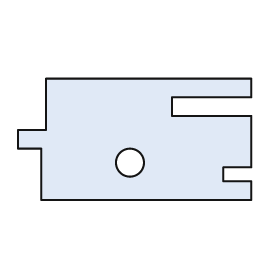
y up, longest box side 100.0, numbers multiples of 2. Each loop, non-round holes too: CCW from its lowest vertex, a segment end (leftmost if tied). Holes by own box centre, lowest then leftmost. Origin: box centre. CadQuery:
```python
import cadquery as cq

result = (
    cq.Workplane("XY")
    .moveTo(-40.0, -26.0)
    .lineTo(50.0, -26.0)
    .lineTo(50.0, -18.0)
    .lineTo(38.0, -18.0)
    .lineTo(38.0, -12.0)
    .lineTo(50.0, -12.0)
    .lineTo(50.0, 10.0)
    .lineTo(16.0, 10.0)
    .lineTo(16.0, 18.0)
    .lineTo(50.0, 18.0)
    .lineTo(50.0, 26.0)
    .lineTo(-38.0, 26.0)
    .lineTo(-38.0, 4.0)
    .lineTo(-50.0, 4.0)
    .lineTo(-50.0, -4.0)
    .lineTo(-40.0, -4.0)
    .close()
    .moveTo(-2.0, -10.0)
    .circle(6.0)
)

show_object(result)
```